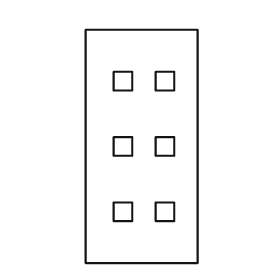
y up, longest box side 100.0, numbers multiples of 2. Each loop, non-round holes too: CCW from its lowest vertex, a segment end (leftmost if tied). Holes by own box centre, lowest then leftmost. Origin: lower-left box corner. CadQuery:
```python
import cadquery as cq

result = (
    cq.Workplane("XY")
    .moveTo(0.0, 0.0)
    .lineTo(48.0, 0.0)
    .lineTo(48.0, 100.0)
    .lineTo(0.0, 100.0)
    .close()
    .moveTo(12.0, 18.0)
    .lineTo(20.0, 18.0)
    .lineTo(20.0, 26.0)
    .lineTo(12.0, 26.0)
    .close()
    .moveTo(30.0, 18.0)
    .lineTo(38.0, 18.0)
    .lineTo(38.0, 26.0)
    .lineTo(30.0, 26.0)
    .close()
    .moveTo(12.0, 46.0)
    .lineTo(20.0, 46.0)
    .lineTo(20.0, 54.0)
    .lineTo(12.0, 54.0)
    .close()
    .moveTo(30.0, 46.0)
    .lineTo(38.0, 46.0)
    .lineTo(38.0, 54.0)
    .lineTo(30.0, 54.0)
    .close()
    .moveTo(12.0, 74.0)
    .lineTo(20.0, 74.0)
    .lineTo(20.0, 82.0)
    .lineTo(12.0, 82.0)
    .close()
    .moveTo(30.0, 74.0)
    .lineTo(38.0, 74.0)
    .lineTo(38.0, 82.0)
    .lineTo(30.0, 82.0)
    .close()
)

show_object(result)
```